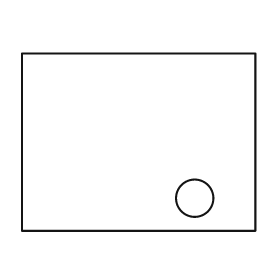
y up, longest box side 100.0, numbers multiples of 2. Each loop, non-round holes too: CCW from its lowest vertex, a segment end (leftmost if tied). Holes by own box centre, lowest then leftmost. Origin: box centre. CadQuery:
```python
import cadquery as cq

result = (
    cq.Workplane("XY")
    .moveTo(-50.0, -38.0)
    .lineTo(50.0, -38.0)
    .lineTo(50.0, 38.0)
    .lineTo(-50.0, 38.0)
    .close()
    .moveTo(24.0, -24.0)
    .circle(8.0)
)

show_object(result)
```